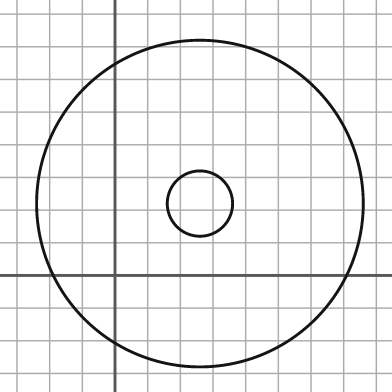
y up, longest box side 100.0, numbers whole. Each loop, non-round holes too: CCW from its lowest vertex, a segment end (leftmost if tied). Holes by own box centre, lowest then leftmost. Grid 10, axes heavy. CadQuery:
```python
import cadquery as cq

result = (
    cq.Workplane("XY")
    .moveTo(26.0, 22.0)
    .circle(50.0)
    .moveTo(26.0, 22.0)
    .circle(10.0)
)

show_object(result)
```